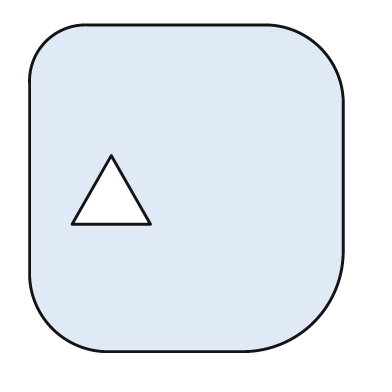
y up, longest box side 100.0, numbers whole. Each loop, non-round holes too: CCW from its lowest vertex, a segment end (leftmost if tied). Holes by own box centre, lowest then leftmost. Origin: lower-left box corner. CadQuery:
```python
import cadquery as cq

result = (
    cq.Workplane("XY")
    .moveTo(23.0, 0.0)
    .lineTo(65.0, 0.0)
    .threePointArc((87.0, 9.0), (96.0, 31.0))
    .lineTo(96.0, 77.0)
    .threePointArc((89.0, 93.0), (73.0, 100.0))
    .lineTo(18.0, 100.0)
    .threePointArc((5.0, 95.0), (0.0, 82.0))
    .lineTo(0.0, 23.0)
    .threePointArc((7.0, 7.0), (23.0, 0.0))
    .close()
    .moveTo(13.0, 39.0)
    .lineTo(37.0, 39.0)
    .lineTo(25.0, 60.0)
    .close()
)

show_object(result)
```